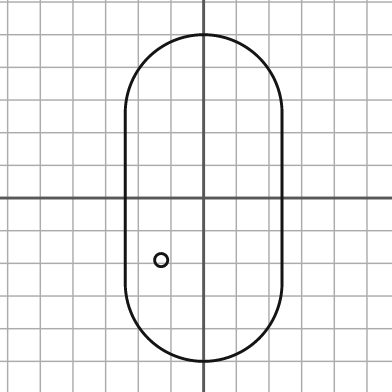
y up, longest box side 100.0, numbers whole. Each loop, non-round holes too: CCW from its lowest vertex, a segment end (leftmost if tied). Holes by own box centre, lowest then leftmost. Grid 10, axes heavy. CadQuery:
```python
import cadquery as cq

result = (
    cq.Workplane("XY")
    .moveTo(-24.0, -26.0)
    .threePointArc((0.0, -50.0), (24.0, -26.0))
    .lineTo(24.0, 26.0)
    .threePointArc((0.0, 50.0), (-24.0, 26.0))
    .close()
    .moveTo(-13.0, -19.0)
    .circle(2.0)
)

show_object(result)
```